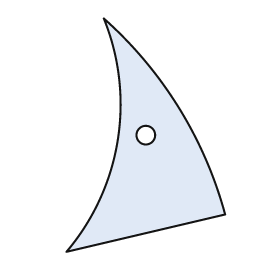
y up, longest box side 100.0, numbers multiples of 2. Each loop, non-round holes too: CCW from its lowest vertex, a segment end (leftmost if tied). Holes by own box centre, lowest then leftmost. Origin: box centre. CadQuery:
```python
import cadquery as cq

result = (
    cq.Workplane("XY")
    .moveTo(-34.0, -50.0)
    .lineTo(34.0, -34.0)
    .threePointArc((14.0, 12.0), (-18.0, 50.0))
    .threePointArc((-12.0, -2.0), (-34.0, -50.0))
    .close()
    .moveTo(0.0, 0.0)
    .circle(4.0)
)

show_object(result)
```